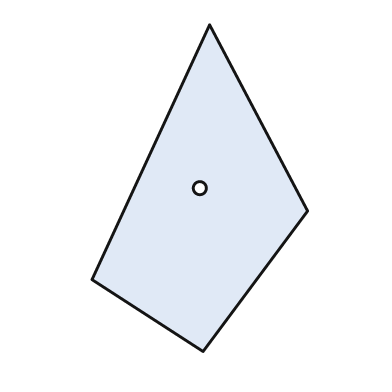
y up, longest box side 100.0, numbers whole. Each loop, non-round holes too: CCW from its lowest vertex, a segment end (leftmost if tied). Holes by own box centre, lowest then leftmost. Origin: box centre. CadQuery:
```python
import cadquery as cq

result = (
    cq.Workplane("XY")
    .moveTo(1.0, -50.0)
    .lineTo(33.0, -7.0)
    .lineTo(3.0, 50.0)
    .lineTo(-33.0, -28.0)
    .close()
    .moveTo(0.0, 0.0)
    .circle(2.0)
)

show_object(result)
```